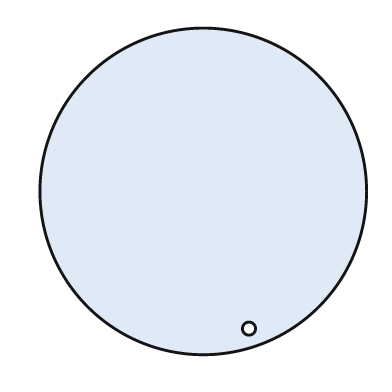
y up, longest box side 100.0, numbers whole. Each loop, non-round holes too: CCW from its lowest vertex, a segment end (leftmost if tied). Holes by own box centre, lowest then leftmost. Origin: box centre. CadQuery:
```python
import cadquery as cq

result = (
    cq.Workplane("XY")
    .moveTo(0.0, 0.0)
    .circle(50.0)
    .moveTo(14.0, -42.0)
    .circle(2.0)
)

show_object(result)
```